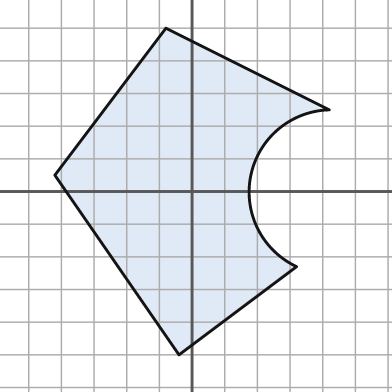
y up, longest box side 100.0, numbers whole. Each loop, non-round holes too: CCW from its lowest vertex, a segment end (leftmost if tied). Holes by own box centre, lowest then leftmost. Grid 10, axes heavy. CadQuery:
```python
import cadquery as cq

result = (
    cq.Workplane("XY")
    .moveTo(-4.0, -50.0)
    .lineTo(32.0, -23.0)
    .threePointArc((18.0, 5.0), (42.0, 25.0))
    .lineTo(-8.0, 50.0)
    .lineTo(-42.0, 5.0)
    .close()
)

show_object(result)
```